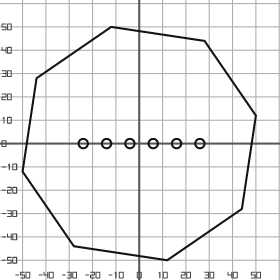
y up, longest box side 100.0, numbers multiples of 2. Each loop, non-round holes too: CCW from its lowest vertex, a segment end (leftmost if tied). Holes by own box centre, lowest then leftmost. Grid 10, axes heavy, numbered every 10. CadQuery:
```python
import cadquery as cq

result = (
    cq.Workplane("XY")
    .moveTo(12.0, -50.0)
    .lineTo(44.0, -28.0)
    .lineTo(50.0, 12.0)
    .lineTo(28.0, 44.0)
    .lineTo(-12.0, 50.0)
    .lineTo(-44.0, 28.0)
    .lineTo(-50.0, -12.0)
    .lineTo(-28.0, -44.0)
    .close()
    .moveTo(-24.0, 0.0)
    .circle(2.0)
    .moveTo(-14.0, 0.0)
    .circle(2.0)
    .moveTo(-4.0, 0.0)
    .circle(2.0)
    .moveTo(6.0, 0.0)
    .circle(2.0)
    .moveTo(16.0, 0.0)
    .circle(2.0)
    .moveTo(26.0, 0.0)
    .circle(2.0)
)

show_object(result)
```